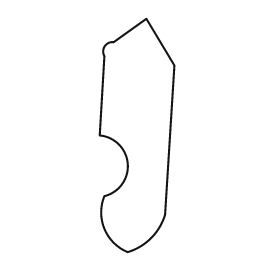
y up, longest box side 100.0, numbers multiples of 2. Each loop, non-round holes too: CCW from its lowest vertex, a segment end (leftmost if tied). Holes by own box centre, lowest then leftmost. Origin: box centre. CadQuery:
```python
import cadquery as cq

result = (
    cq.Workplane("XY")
    .moveTo(-4.0, -50.0)
    .threePointArc((6.0, -44.0), (12.0, -34.0))
    .lineTo(16.0, 30.0)
    .lineTo(4.0, 50.0)
    .lineTo(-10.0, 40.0)
    .threePointArc((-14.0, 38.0), (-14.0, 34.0))
    .lineTo(-16.0, 0.0)
    .threePointArc((-4.0, -12.0), (-14.0, -26.0))
    .threePointArc((-14.0, -40.0), (-4.0, -50.0))
    .close()
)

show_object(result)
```